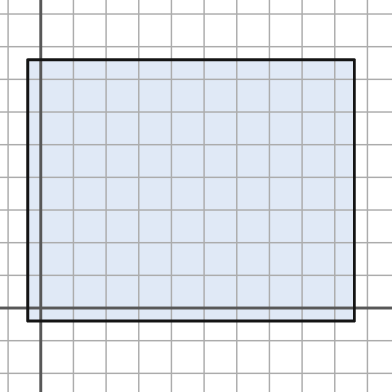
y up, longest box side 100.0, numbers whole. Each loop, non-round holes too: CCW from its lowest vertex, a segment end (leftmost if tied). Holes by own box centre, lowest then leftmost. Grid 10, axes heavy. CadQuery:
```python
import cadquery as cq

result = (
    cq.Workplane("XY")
    .moveTo(-4.0, -4.0)
    .lineTo(96.0, -4.0)
    .lineTo(96.0, 76.0)
    .lineTo(-4.0, 76.0)
    .close()
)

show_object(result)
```